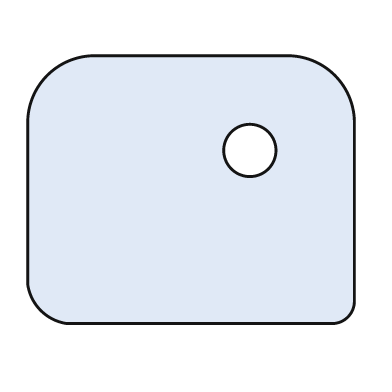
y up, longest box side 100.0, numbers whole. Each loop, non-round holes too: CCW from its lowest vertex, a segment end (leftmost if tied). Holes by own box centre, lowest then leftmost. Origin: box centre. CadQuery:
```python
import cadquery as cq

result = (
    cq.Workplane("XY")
    .moveTo(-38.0, -41.0)
    .lineTo(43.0, -41.0)
    .threePointArc((48.0, -39.0), (50.0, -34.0))
    .lineTo(50.0, 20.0)
    .threePointArc((44.0, 35.0), (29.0, 41.0))
    .lineTo(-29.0, 41.0)
    .threePointArc((-44.0, 35.0), (-50.0, 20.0))
    .lineTo(-50.0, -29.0)
    .threePointArc((-46.0, -37.0), (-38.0, -41.0))
    .close()
    .moveTo(18.0, 12.0)
    .circle(8.0)
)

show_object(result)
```